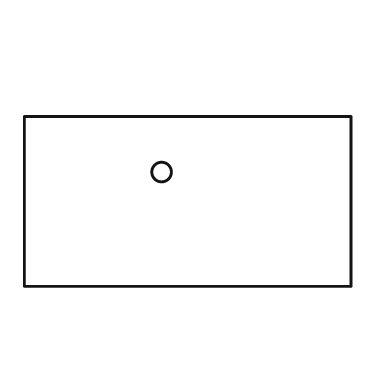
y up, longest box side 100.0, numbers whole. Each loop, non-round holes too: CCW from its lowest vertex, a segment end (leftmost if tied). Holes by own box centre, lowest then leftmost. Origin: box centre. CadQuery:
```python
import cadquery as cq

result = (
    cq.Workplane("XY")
    .moveTo(-50.0, -26.0)
    .lineTo(50.0, -26.0)
    .lineTo(50.0, 26.0)
    .lineTo(-50.0, 26.0)
    .close()
    .moveTo(-8.0, 9.0)
    .circle(3.0)
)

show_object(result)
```